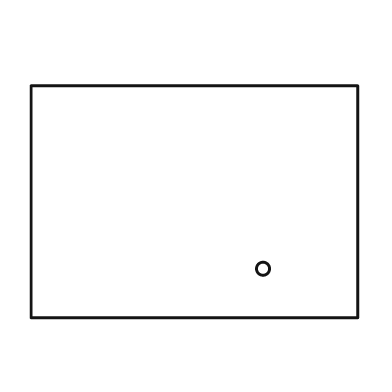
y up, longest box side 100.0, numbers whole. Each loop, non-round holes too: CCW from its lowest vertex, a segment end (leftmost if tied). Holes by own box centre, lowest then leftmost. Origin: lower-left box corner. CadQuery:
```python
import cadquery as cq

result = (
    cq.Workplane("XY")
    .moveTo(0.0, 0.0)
    .lineTo(100.0, 0.0)
    .lineTo(100.0, 71.0)
    .lineTo(0.0, 71.0)
    .close()
    .moveTo(71.0, 15.0)
    .circle(2.0)
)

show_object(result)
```